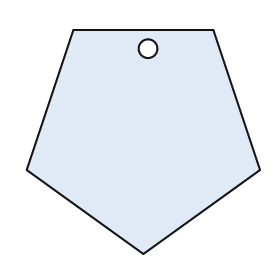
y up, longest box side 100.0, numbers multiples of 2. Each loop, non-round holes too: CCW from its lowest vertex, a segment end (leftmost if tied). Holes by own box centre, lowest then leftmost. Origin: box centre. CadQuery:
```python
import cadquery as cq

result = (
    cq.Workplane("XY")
    .moveTo(0.0, -48.0)
    .lineTo(50.0, -12.0)
    .lineTo(30.0, 48.0)
    .lineTo(-30.0, 48.0)
    .lineTo(-50.0, -12.0)
    .close()
    .moveTo(2.0, 40.0)
    .circle(4.0)
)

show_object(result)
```